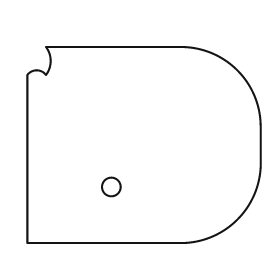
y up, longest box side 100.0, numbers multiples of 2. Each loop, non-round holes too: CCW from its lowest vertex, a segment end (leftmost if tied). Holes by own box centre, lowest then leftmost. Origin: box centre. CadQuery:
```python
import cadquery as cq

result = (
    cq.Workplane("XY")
    .moveTo(-50.0, -42.0)
    .lineTo(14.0, -42.0)
    .threePointArc((40.0, -32.0), (50.0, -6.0))
    .lineTo(50.0, 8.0)
    .threePointArc((40.0, 32.0), (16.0, 42.0))
    .lineTo(-42.0, 42.0)
    .threePointArc((-40.0, 36.0), (-42.0, 30.0))
    .threePointArc((-46.0, 32.0), (-50.0, 30.0))
    .close()
    .moveTo(-14.0, -18.0)
    .circle(4.0)
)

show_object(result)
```